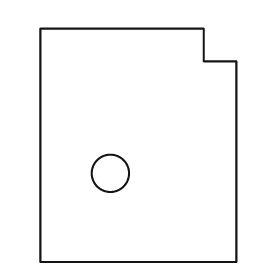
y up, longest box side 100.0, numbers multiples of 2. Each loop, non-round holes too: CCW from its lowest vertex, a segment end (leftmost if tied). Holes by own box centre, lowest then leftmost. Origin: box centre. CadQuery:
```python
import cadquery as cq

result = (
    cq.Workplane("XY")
    .moveTo(-42.0, -50.0)
    .lineTo(42.0, -50.0)
    .lineTo(42.0, 36.0)
    .lineTo(28.0, 36.0)
    .lineTo(28.0, 50.0)
    .lineTo(-42.0, 50.0)
    .close()
    .moveTo(-12.0, -12.0)
    .circle(8.0)
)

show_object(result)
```